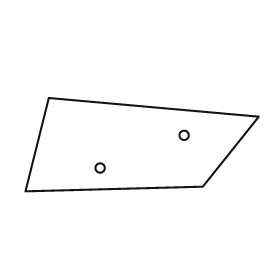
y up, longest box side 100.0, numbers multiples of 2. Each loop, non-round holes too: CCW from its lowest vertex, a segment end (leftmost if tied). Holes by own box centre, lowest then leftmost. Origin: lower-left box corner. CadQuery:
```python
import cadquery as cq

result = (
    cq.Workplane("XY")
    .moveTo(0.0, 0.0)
    .lineTo(76.0, 2.0)
    .lineTo(100.0, 32.0)
    .lineTo(10.0, 40.0)
    .close()
    .moveTo(32.0, 10.0)
    .circle(2.0)
    .moveTo(68.0, 24.0)
    .circle(2.0)
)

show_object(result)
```